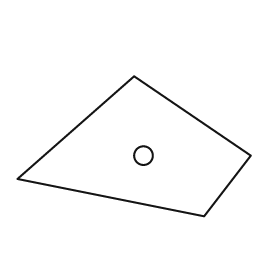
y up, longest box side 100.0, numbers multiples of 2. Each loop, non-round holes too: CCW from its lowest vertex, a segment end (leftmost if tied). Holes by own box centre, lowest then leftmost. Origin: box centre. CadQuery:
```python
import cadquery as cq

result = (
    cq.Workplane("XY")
    .moveTo(30.0, -30.0)
    .lineTo(50.0, -4.0)
    .lineTo(0.0, 30.0)
    .lineTo(-50.0, -14.0)
    .close()
    .moveTo(4.0, -4.0)
    .circle(4.0)
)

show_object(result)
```